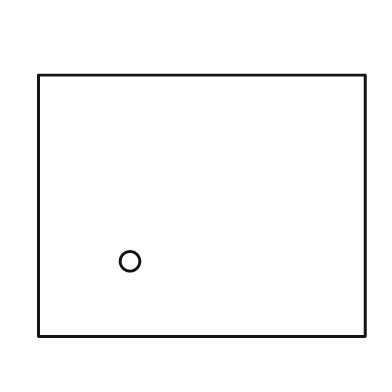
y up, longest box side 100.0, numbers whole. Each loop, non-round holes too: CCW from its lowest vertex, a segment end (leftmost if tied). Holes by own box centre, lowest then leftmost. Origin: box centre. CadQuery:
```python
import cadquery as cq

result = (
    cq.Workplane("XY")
    .moveTo(-50.0, -40.0)
    .lineTo(50.0, -40.0)
    .lineTo(50.0, 40.0)
    .lineTo(-50.0, 40.0)
    .close()
    .moveTo(-22.0, -17.0)
    .circle(3.0)
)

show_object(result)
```